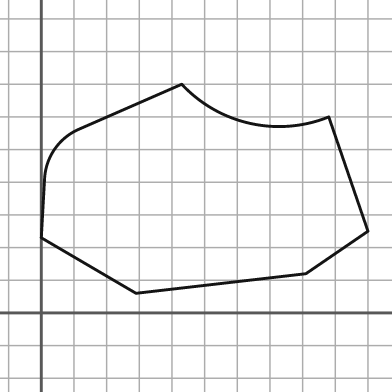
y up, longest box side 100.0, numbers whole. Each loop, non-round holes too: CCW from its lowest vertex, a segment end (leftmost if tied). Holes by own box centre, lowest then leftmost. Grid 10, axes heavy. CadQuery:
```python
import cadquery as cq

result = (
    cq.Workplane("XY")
    .moveTo(29.0, 6.0)
    .lineTo(81.0, 12.0)
    .lineTo(100.0, 25.0)
    .lineTo(88.0, 60.0)
    .threePointArc((64.0, 58.0), (43.0, 70.0))
    .lineTo(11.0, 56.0)
    .threePointArc((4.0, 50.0), (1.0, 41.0))
    .lineTo(0.0, 23.0)
    .close()
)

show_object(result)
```